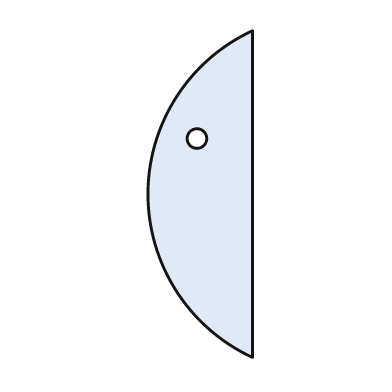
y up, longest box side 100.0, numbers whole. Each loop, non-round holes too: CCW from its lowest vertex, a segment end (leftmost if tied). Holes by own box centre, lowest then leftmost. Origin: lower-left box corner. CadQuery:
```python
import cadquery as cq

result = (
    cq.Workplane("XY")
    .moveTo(32.0, 0.0)
    .lineTo(32.0, 100.0)
    .threePointArc((0.0, 50.0), (32.0, 0.0))
    .close()
    .moveTo(15.0, 67.0)
    .circle(3.0)
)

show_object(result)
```